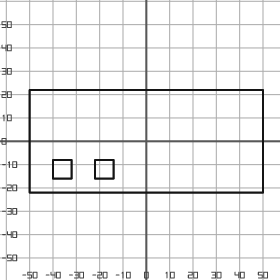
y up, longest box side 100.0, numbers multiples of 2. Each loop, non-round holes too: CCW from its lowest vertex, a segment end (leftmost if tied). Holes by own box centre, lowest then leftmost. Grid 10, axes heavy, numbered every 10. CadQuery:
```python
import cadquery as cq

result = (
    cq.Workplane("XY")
    .moveTo(-50.0, -22.0)
    .lineTo(50.0, -22.0)
    .lineTo(50.0, 22.0)
    .lineTo(-50.0, 22.0)
    .close()
    .moveTo(-40.0, -16.0)
    .lineTo(-32.0, -16.0)
    .lineTo(-32.0, -8.0)
    .lineTo(-40.0, -8.0)
    .close()
    .moveTo(-22.0, -16.0)
    .lineTo(-14.0, -16.0)
    .lineTo(-14.0, -8.0)
    .lineTo(-22.0, -8.0)
    .close()
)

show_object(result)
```